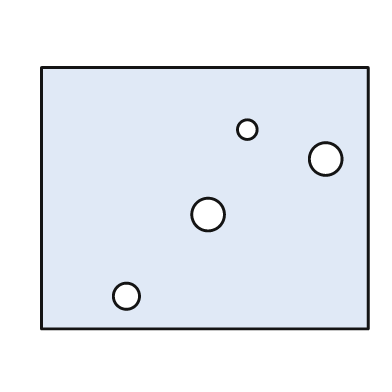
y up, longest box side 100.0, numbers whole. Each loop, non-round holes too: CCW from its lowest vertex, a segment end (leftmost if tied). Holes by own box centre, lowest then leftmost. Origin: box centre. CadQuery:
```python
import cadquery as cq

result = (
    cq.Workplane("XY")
    .moveTo(-50.0, -40.0)
    .lineTo(50.0, -40.0)
    .lineTo(50.0, 40.0)
    .lineTo(-50.0, 40.0)
    .close()
    .moveTo(-24.0, -30.0)
    .circle(4.0)
    .moveTo(1.0, -5.0)
    .circle(5.0)
    .moveTo(37.0, 12.0)
    .circle(5.0)
    .moveTo(13.0, 21.0)
    .circle(3.0)
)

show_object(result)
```